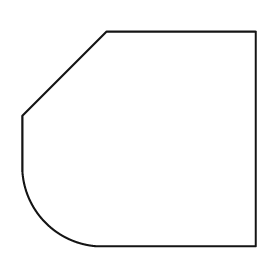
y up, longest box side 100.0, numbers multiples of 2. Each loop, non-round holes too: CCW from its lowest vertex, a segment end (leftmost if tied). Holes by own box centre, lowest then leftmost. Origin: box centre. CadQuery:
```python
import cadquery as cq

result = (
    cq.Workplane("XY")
    .moveTo(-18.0, -46.0)
    .lineTo(50.0, -46.0)
    .lineTo(50.0, 46.0)
    .lineTo(-14.0, 46.0)
    .lineTo(-50.0, 10.0)
    .lineTo(-50.0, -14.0)
    .threePointArc((-40.0, -36.0), (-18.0, -46.0))
    .close()
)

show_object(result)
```